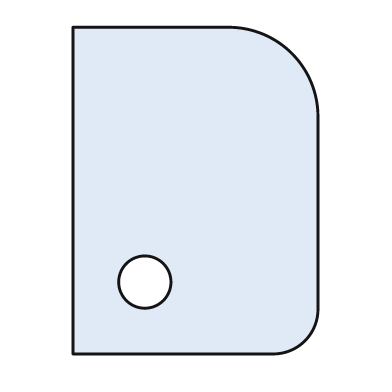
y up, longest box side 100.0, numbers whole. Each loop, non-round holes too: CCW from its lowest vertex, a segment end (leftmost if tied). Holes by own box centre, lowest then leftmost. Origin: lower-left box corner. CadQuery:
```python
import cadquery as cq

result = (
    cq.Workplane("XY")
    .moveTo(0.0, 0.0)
    .lineTo(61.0, 0.0)
    .threePointArc((71.0, 4.0), (75.0, 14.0))
    .lineTo(75.0, 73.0)
    .threePointArc((67.0, 92.0), (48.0, 100.0))
    .lineTo(0.0, 100.0)
    .close()
    .moveTo(22.0, 22.0)
    .circle(8.0)
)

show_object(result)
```